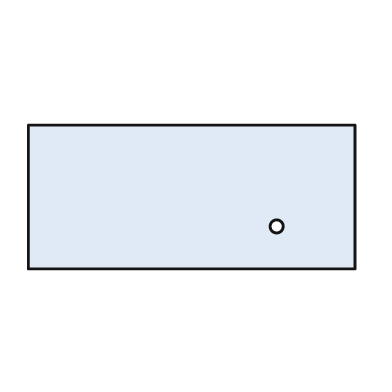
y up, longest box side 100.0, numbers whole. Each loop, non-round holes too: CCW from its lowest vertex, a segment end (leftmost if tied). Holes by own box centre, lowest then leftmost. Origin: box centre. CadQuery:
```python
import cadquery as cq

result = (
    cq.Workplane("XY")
    .moveTo(-50.0, -22.0)
    .lineTo(50.0, -22.0)
    .lineTo(50.0, 22.0)
    .lineTo(-50.0, 22.0)
    .close()
    .moveTo(26.0, -9.0)
    .circle(2.0)
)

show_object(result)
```